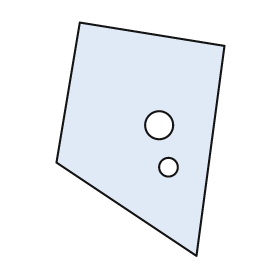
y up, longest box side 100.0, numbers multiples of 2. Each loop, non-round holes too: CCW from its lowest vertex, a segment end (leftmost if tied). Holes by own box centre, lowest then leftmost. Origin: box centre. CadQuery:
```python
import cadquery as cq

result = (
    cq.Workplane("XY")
    .moveTo(24.0, -50.0)
    .lineTo(36.0, 40.0)
    .lineTo(-26.0, 50.0)
    .lineTo(-36.0, -10.0)
    .close()
    .moveTo(12.0, -12.0)
    .circle(4.0)
    .moveTo(8.0, 6.0)
    .circle(6.0)
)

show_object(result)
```